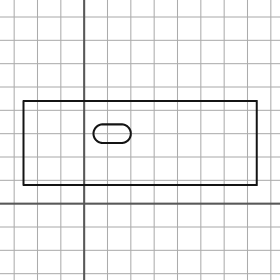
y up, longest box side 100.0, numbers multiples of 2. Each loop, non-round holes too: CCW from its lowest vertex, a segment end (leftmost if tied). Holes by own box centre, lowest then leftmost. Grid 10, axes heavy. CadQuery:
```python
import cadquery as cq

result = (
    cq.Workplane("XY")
    .moveTo(-26.0, 8.0)
    .lineTo(74.0, 8.0)
    .lineTo(74.0, 44.0)
    .lineTo(-26.0, 44.0)
    .close()
    .moveTo(8.0, 26.0)
    .lineTo(16.0, 26.0)
    .threePointArc((20.0, 30.0), (16.0, 34.0))
    .lineTo(8.0, 34.0)
    .threePointArc((4.0, 30.0), (8.0, 26.0))
    .close()
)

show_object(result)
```